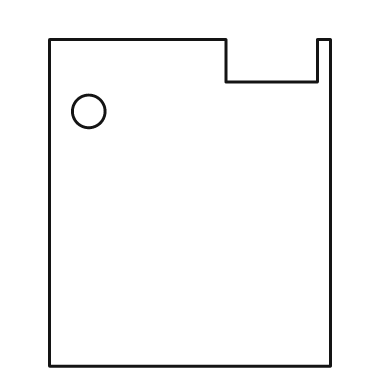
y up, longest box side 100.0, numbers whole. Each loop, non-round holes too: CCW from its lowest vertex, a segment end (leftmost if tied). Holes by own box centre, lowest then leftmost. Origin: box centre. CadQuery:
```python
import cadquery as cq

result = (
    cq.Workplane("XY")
    .moveTo(-43.0, -50.0)
    .lineTo(43.0, -50.0)
    .lineTo(43.0, 50.0)
    .lineTo(39.0, 50.0)
    .lineTo(39.0, 37.0)
    .lineTo(11.0, 37.0)
    .lineTo(11.0, 50.0)
    .lineTo(-43.0, 50.0)
    .close()
    .moveTo(-31.0, 28.0)
    .circle(5.0)
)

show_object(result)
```